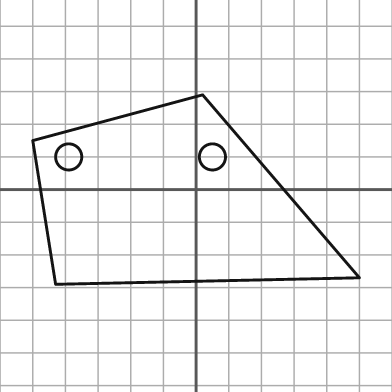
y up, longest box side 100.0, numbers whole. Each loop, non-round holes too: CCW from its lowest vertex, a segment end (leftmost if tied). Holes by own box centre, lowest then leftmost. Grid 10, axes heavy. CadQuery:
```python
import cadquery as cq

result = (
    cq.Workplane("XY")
    .moveTo(-43.0, -29.0)
    .lineTo(50.0, -27.0)
    .lineTo(2.0, 29.0)
    .lineTo(-50.0, 15.0)
    .close()
    .moveTo(-39.0, 10.0)
    .circle(4.0)
    .moveTo(5.0, 10.0)
    .circle(4.0)
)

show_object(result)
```